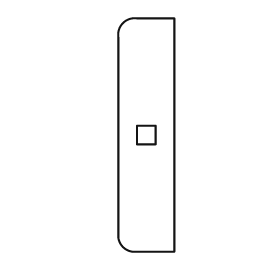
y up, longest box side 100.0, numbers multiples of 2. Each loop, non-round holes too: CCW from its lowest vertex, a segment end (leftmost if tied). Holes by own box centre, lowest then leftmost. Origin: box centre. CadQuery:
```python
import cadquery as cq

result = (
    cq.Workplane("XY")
    .moveTo(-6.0, -50.0)
    .lineTo(12.0, -50.0)
    .lineTo(12.0, 50.0)
    .lineTo(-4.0, 50.0)
    .threePointArc((-10.0, 48.0), (-12.0, 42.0))
    .lineTo(-12.0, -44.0)
    .threePointArc((-10.0, -48.0), (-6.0, -50.0))
    .close()
    .moveTo(-4.0, -4.0)
    .lineTo(4.0, -4.0)
    .lineTo(4.0, 4.0)
    .lineTo(-4.0, 4.0)
    .close()
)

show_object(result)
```